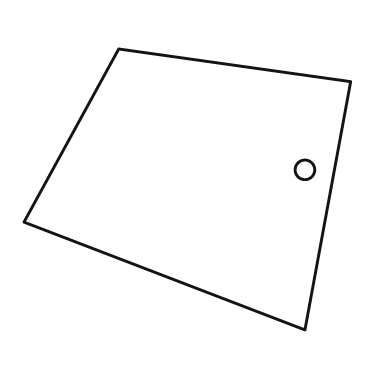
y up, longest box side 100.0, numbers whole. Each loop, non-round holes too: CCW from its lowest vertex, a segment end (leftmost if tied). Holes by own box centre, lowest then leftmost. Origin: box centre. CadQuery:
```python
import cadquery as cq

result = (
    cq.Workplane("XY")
    .moveTo(36.0, -43.0)
    .lineTo(50.0, 33.0)
    .lineTo(-21.0, 43.0)
    .lineTo(-50.0, -10.0)
    .close()
    .moveTo(36.0, 6.0)
    .circle(3.0)
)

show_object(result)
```